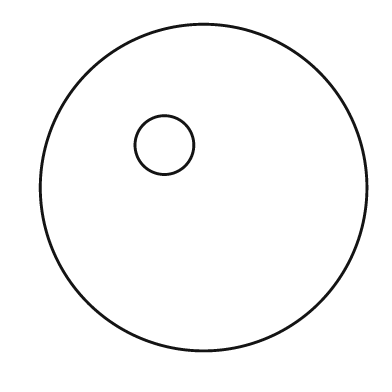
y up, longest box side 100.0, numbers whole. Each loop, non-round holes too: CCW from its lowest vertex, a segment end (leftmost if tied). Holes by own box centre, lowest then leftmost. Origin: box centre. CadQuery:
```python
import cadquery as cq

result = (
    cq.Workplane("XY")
    .moveTo(0.0, 0.0)
    .circle(50.0)
    .moveTo(-12.0, 13.0)
    .circle(9.0)
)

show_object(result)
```